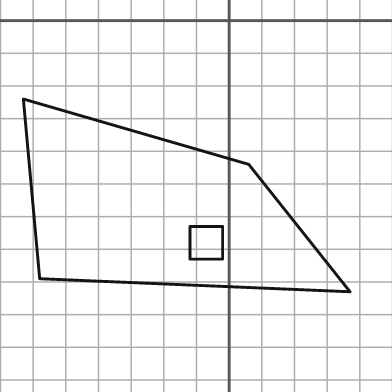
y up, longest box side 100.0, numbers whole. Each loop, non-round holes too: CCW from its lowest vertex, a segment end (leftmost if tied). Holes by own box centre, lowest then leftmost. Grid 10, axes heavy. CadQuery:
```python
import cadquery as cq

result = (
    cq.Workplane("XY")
    .moveTo(37.0, -83.0)
    .lineTo(6.0, -44.0)
    .lineTo(-63.0, -24.0)
    .lineTo(-58.0, -79.0)
    .close()
    .moveTo(-12.0, -73.0)
    .lineTo(-2.0, -73.0)
    .lineTo(-2.0, -63.0)
    .lineTo(-12.0, -63.0)
    .close()
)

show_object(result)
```